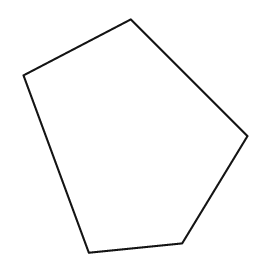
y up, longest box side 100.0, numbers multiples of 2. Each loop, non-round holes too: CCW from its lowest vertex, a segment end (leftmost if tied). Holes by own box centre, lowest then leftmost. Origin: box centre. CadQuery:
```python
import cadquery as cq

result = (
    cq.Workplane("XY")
    .moveTo(-20.0, -50.0)
    .lineTo(20.0, -46.0)
    .lineTo(48.0, 0.0)
    .lineTo(-2.0, 50.0)
    .lineTo(-48.0, 26.0)
    .close()
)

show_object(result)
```